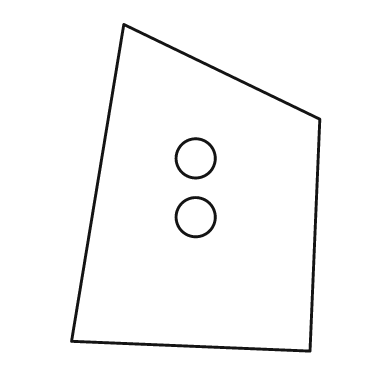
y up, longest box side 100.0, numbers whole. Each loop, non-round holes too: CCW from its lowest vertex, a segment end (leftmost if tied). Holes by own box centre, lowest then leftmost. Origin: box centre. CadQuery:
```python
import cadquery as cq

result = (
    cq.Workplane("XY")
    .moveTo(35.0, -50.0)
    .lineTo(38.0, 21.0)
    .lineTo(-22.0, 50.0)
    .lineTo(-38.0, -47.0)
    .close()
    .moveTo(0.0, -9.0)
    .circle(6.0)
    .moveTo(0.0, 9.0)
    .circle(6.0)
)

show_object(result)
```